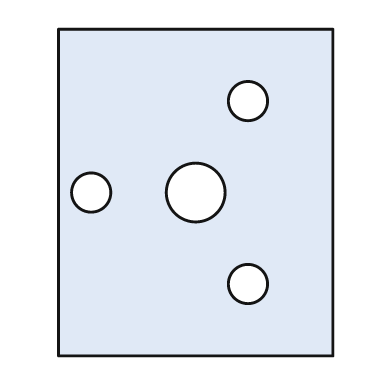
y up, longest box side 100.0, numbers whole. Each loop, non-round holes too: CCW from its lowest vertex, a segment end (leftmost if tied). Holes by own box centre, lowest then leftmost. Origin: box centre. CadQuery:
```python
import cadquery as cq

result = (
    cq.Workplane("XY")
    .moveTo(-42.0, -50.0)
    .lineTo(42.0, -50.0)
    .lineTo(42.0, 50.0)
    .lineTo(-42.0, 50.0)
    .close()
    .moveTo(16.0, -28.0)
    .circle(6.0)
    .moveTo(-32.0, 0.0)
    .circle(6.0)
    .moveTo(0.0, 0.0)
    .circle(9.0)
    .moveTo(16.0, 28.0)
    .circle(6.0)
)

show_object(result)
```